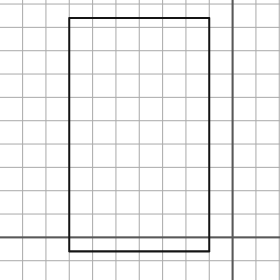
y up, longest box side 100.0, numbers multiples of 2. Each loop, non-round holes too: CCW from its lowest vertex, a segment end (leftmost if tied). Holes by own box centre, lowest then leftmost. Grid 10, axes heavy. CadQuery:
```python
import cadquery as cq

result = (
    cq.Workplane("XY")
    .moveTo(-70.0, -6.0)
    .lineTo(-10.0, -6.0)
    .lineTo(-10.0, 94.0)
    .lineTo(-70.0, 94.0)
    .close()
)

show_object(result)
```